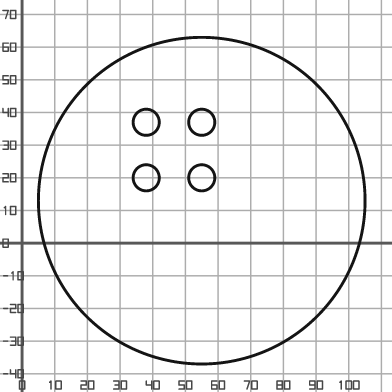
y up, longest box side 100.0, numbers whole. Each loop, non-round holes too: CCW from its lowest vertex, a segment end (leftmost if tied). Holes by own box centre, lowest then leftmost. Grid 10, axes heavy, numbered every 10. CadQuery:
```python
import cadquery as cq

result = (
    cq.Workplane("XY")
    .moveTo(55.0, 13.0)
    .circle(50.0)
    .moveTo(38.0, 20.0)
    .circle(4.0)
    .moveTo(55.0, 20.0)
    .circle(4.0)
    .moveTo(38.0, 37.0)
    .circle(4.0)
    .moveTo(55.0, 37.0)
    .circle(4.0)
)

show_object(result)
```